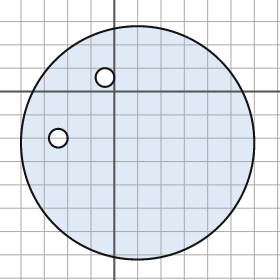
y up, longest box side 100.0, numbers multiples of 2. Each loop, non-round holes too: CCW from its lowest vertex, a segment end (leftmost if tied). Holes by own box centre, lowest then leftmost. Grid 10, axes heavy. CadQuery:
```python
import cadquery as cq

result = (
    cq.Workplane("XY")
    .moveTo(10.0, -22.0)
    .circle(50.0)
    .moveTo(-24.0, -20.0)
    .circle(4.0)
    .moveTo(-4.0, 6.0)
    .circle(4.0)
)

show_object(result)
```